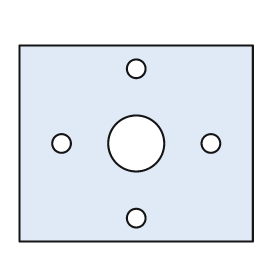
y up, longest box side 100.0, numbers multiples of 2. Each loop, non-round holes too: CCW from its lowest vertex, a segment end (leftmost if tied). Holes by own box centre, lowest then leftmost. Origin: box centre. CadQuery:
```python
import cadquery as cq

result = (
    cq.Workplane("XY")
    .moveTo(-50.0, -42.0)
    .lineTo(50.0, -42.0)
    .lineTo(50.0, 42.0)
    .lineTo(-50.0, 42.0)
    .close()
    .moveTo(0.0, -32.0)
    .circle(4.0)
    .moveTo(-32.0, 0.0)
    .circle(4.0)
    .moveTo(0.0, 0.0)
    .circle(12.0)
    .moveTo(32.0, 0.0)
    .circle(4.0)
    .moveTo(0.0, 32.0)
    .circle(4.0)
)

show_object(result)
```